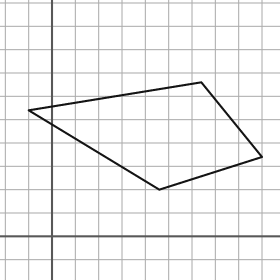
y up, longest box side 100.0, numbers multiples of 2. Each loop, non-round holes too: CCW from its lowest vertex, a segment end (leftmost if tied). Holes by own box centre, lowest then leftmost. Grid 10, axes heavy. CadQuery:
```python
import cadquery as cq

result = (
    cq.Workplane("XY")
    .moveTo(46.0, 20.0)
    .lineTo(90.0, 34.0)
    .lineTo(64.0, 66.0)
    .lineTo(-10.0, 54.0)
    .close()
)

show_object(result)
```